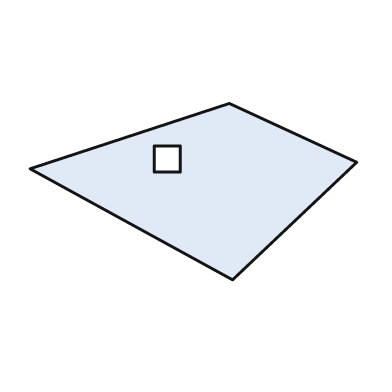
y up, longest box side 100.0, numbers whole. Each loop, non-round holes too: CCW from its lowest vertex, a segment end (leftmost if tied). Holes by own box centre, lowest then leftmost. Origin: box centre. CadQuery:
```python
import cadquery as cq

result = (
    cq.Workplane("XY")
    .moveTo(12.0, -27.0)
    .lineTo(50.0, 9.0)
    .lineTo(11.0, 27.0)
    .lineTo(-50.0, 7.0)
    .close()
    .moveTo(-12.0, 6.0)
    .lineTo(-4.0, 6.0)
    .lineTo(-4.0, 14.0)
    .lineTo(-12.0, 14.0)
    .close()
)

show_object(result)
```